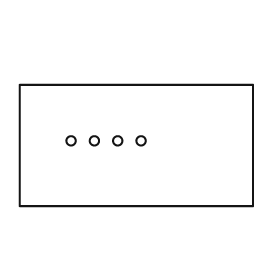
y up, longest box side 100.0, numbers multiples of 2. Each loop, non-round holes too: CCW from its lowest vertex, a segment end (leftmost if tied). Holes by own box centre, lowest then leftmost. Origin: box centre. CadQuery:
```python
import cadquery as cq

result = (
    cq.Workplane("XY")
    .moveTo(-50.0, -26.0)
    .lineTo(50.0, -26.0)
    .lineTo(50.0, 26.0)
    .lineTo(-50.0, 26.0)
    .close()
    .moveTo(-28.0, 2.0)
    .circle(2.0)
    .moveTo(-18.0, 2.0)
    .circle(2.0)
    .moveTo(-8.0, 2.0)
    .circle(2.0)
    .moveTo(2.0, 2.0)
    .circle(2.0)
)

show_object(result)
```